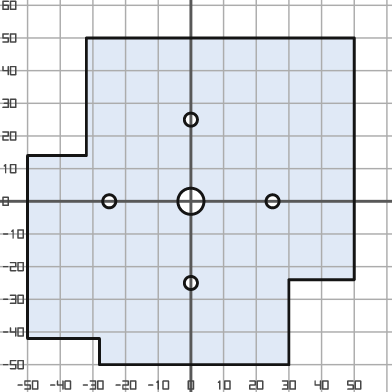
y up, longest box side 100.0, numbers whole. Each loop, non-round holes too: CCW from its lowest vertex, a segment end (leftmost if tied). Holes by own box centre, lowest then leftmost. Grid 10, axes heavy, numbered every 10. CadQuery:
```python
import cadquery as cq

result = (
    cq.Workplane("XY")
    .moveTo(-28.0, -50.0)
    .lineTo(30.0, -50.0)
    .lineTo(30.0, -24.0)
    .lineTo(50.0, -24.0)
    .lineTo(50.0, 50.0)
    .lineTo(-32.0, 50.0)
    .lineTo(-32.0, 14.0)
    .lineTo(-50.0, 14.0)
    .lineTo(-50.0, -42.0)
    .lineTo(-28.0, -42.0)
    .close()
    .moveTo(0.0, -25.0)
    .circle(2.0)
    .moveTo(-25.0, 0.0)
    .circle(2.0)
    .moveTo(0.0, 0.0)
    .circle(4.0)
    .moveTo(25.0, 0.0)
    .circle(2.0)
    .moveTo(0.0, 25.0)
    .circle(2.0)
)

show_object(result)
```